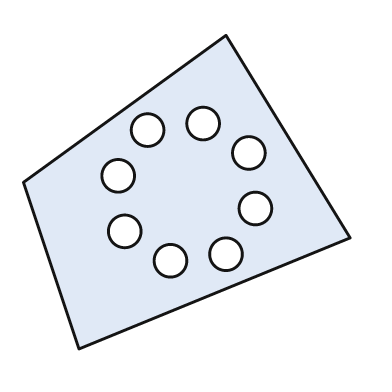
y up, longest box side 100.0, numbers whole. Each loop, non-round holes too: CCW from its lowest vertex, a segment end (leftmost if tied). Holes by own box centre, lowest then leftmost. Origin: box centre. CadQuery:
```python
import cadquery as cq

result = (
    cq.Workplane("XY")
    .moveTo(-33.0, -48.0)
    .lineTo(50.0, -14.0)
    .lineTo(12.0, 48.0)
    .lineTo(-50.0, 3.0)
    .close()
    .moveTo(-5.0, -21.0)
    .circle(5.0)
    .moveTo(12.0, -19.0)
    .circle(5.0)
    .moveTo(-19.0, -12.0)
    .circle(5.0)
    .moveTo(21.0, -5.0)
    .circle(5.0)
    .moveTo(-21.0, 5.0)
    .circle(5.0)
    .moveTo(19.0, 12.0)
    .circle(5.0)
    .moveTo(-12.0, 19.0)
    .circle(5.0)
    .moveTo(5.0, 21.0)
    .circle(5.0)
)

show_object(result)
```